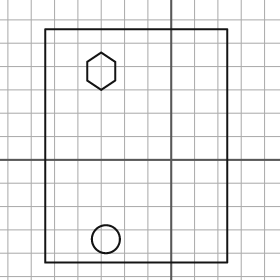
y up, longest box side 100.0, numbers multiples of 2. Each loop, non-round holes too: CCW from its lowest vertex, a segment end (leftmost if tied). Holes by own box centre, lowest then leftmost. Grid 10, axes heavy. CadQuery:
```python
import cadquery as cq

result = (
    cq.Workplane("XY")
    .moveTo(-54.0, -44.0)
    .lineTo(24.0, -44.0)
    .lineTo(24.0, 56.0)
    .lineTo(-54.0, 56.0)
    .close()
    .moveTo(-28.0, -34.0)
    .circle(6.0)
    .moveTo(-30.0, 30.0)
    .lineTo(-24.0, 34.0)
    .lineTo(-24.0, 42.0)
    .lineTo(-30.0, 46.0)
    .lineTo(-36.0, 42.0)
    .lineTo(-36.0, 34.0)
    .close()
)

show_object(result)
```